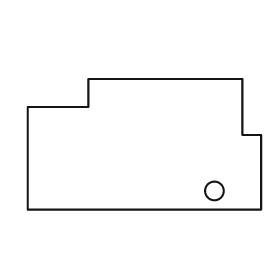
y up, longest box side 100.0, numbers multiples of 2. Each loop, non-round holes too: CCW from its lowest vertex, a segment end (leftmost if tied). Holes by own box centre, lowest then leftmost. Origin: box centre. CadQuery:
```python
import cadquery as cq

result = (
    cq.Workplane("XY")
    .moveTo(-50.0, -28.0)
    .lineTo(50.0, -28.0)
    .lineTo(50.0, 4.0)
    .lineTo(42.0, 4.0)
    .lineTo(42.0, 28.0)
    .lineTo(-24.0, 28.0)
    .lineTo(-24.0, 16.0)
    .lineTo(-50.0, 16.0)
    .close()
    .moveTo(30.0, -20.0)
    .circle(4.0)
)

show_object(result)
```